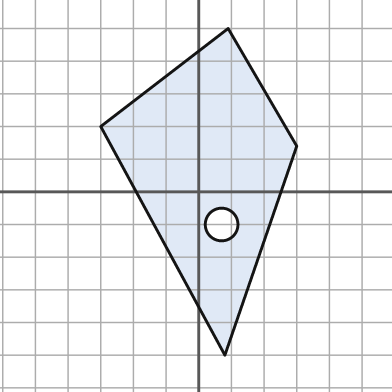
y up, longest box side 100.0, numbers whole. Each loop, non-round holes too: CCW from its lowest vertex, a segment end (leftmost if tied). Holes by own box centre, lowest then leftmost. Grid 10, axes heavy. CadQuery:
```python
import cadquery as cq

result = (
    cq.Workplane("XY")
    .moveTo(8.0, -50.0)
    .lineTo(30.0, 14.0)
    .lineTo(9.0, 50.0)
    .lineTo(-30.0, 20.0)
    .close()
    .moveTo(7.0, -10.0)
    .circle(5.0)
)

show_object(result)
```